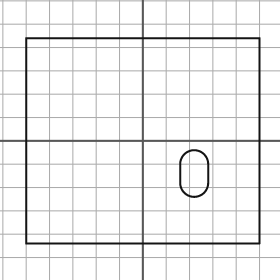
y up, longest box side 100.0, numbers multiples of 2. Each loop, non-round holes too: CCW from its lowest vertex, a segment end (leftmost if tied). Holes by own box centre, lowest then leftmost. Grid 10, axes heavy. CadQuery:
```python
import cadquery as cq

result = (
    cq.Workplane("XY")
    .moveTo(-50.0, -44.0)
    .lineTo(50.0, -44.0)
    .lineTo(50.0, 44.0)
    .lineTo(-50.0, 44.0)
    .close()
    .moveTo(16.0, -18.0)
    .threePointArc((22.0, -24.0), (28.0, -18.0))
    .lineTo(28.0, -10.0)
    .threePointArc((22.0, -4.0), (16.0, -10.0))
    .close()
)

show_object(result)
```